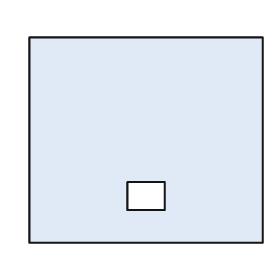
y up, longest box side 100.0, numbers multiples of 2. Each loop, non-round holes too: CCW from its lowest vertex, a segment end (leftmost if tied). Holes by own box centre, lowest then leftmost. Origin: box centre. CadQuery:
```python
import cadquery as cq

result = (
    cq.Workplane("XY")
    .moveTo(-50.0, -44.0)
    .lineTo(50.0, -44.0)
    .lineTo(50.0, 44.0)
    .lineTo(-50.0, 44.0)
    .close()
    .moveTo(-8.0, -30.0)
    .lineTo(8.0, -30.0)
    .lineTo(8.0, -18.0)
    .lineTo(-8.0, -18.0)
    .close()
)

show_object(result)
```